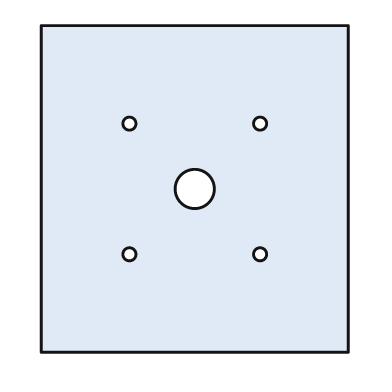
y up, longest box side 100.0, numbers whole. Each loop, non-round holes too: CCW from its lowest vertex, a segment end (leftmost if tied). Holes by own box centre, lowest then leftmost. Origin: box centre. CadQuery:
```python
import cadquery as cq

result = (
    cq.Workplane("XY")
    .moveTo(-47.0, -50.0)
    .lineTo(47.0, -50.0)
    .lineTo(47.0, 50.0)
    .lineTo(-47.0, 50.0)
    .close()
    .moveTo(-20.0, -20.0)
    .circle(2.0)
    .moveTo(20.0, -20.0)
    .circle(2.0)
    .moveTo(0.0, 0.0)
    .circle(6.0)
    .moveTo(-20.0, 20.0)
    .circle(2.0)
    .moveTo(20.0, 20.0)
    .circle(2.0)
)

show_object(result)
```